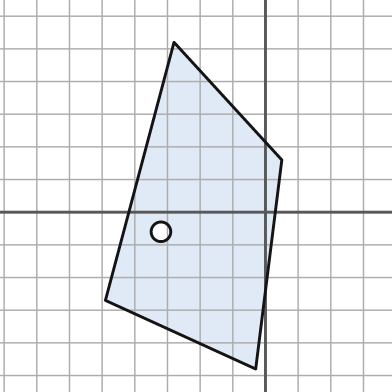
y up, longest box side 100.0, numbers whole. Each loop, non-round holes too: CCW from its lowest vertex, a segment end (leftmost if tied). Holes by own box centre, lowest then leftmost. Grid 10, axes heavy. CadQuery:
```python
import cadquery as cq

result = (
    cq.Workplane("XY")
    .moveTo(-3.0, -48.0)
    .lineTo(5.0, 16.0)
    .lineTo(-28.0, 52.0)
    .lineTo(-49.0, -27.0)
    .close()
    .moveTo(-32.0, -6.0)
    .circle(3.0)
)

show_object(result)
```